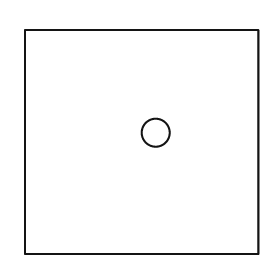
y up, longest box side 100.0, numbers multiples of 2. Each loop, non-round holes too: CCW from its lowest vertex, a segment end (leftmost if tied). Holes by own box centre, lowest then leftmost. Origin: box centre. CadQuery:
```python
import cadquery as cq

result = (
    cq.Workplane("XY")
    .moveTo(-50.0, -48.0)
    .lineTo(50.0, -48.0)
    .lineTo(50.0, 48.0)
    .lineTo(-50.0, 48.0)
    .close()
    .moveTo(6.0, 4.0)
    .circle(6.0)
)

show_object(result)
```